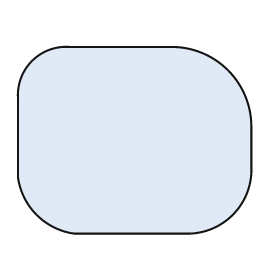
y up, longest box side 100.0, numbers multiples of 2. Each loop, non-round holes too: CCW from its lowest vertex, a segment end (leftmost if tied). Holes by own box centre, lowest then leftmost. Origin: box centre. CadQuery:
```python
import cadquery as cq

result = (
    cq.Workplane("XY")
    .moveTo(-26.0, -40.0)
    .lineTo(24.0, -40.0)
    .threePointArc((42.0, -32.0), (50.0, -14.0))
    .lineTo(50.0, 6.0)
    .threePointArc((40.0, 30.0), (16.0, 40.0))
    .lineTo(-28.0, 40.0)
    .threePointArc((-44.0, 34.0), (-50.0, 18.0))
    .lineTo(-50.0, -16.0)
    .threePointArc((-42.0, -32.0), (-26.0, -40.0))
    .close()
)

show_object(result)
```